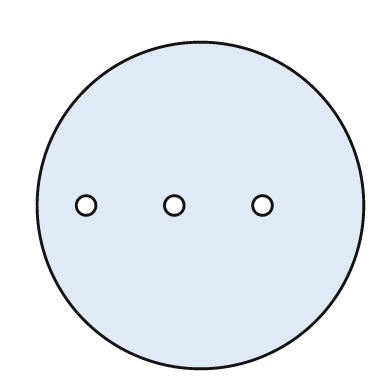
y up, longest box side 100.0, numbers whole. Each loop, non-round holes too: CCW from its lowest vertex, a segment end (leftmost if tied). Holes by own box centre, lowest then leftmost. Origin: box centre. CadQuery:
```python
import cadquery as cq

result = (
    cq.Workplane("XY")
    .moveTo(0.0, 0.0)
    .circle(50.0)
    .moveTo(-35.0, 0.0)
    .circle(3.0)
    .moveTo(-8.0, 0.0)
    .circle(3.0)
    .moveTo(19.0, 0.0)
    .circle(3.0)
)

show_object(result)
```